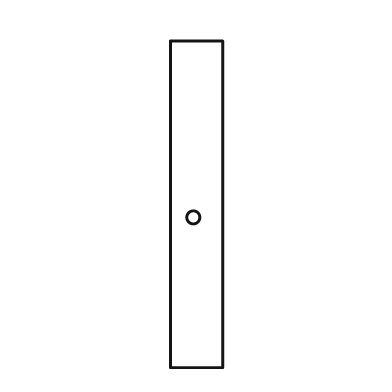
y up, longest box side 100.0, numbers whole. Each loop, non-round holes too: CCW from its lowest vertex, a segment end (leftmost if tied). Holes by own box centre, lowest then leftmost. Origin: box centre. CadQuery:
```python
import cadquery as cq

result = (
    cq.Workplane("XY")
    .moveTo(-8.0, -50.0)
    .lineTo(8.0, -50.0)
    .lineTo(8.0, 50.0)
    .lineTo(-8.0, 50.0)
    .close()
    .moveTo(-1.0, -4.0)
    .circle(2.0)
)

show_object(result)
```